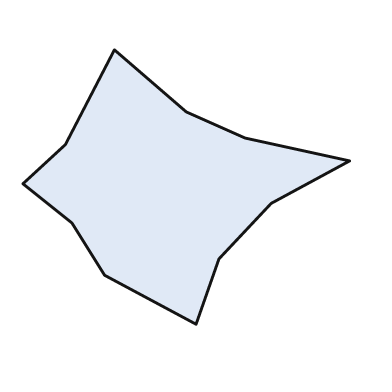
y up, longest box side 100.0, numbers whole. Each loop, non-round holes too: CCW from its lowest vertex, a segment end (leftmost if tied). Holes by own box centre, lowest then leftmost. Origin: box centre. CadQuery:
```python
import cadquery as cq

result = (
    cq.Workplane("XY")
    .moveTo(3.0, -42.0)
    .lineTo(10.0, -22.0)
    .lineTo(26.0, -5.0)
    .lineTo(50.0, 8.0)
    .lineTo(18.0, 15.0)
    .lineTo(0.0, 23.0)
    .lineTo(-22.0, 42.0)
    .lineTo(-37.0, 13.0)
    .lineTo(-50.0, 1.0)
    .lineTo(-35.0, -11.0)
    .lineTo(-25.0, -27.0)
    .close()
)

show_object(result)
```